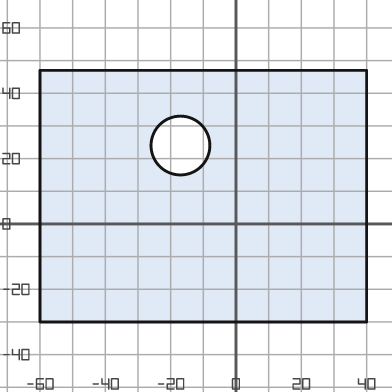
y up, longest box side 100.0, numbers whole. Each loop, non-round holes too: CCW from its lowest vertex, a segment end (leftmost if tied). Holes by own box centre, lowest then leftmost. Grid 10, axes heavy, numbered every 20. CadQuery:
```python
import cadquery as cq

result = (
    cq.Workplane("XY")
    .moveTo(-60.0, -30.0)
    .lineTo(40.0, -30.0)
    .lineTo(40.0, 47.0)
    .lineTo(-60.0, 47.0)
    .close()
    .moveTo(-17.0, 24.0)
    .circle(9.0)
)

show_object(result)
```